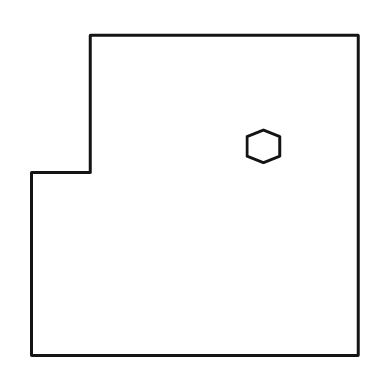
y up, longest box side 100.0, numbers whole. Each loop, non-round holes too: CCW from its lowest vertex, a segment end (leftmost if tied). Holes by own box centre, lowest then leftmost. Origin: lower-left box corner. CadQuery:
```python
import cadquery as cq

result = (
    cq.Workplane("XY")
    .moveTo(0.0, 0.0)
    .lineTo(100.0, 0.0)
    .lineTo(100.0, 98.0)
    .lineTo(18.0, 98.0)
    .lineTo(18.0, 56.0)
    .lineTo(0.0, 56.0)
    .close()
    .moveTo(71.0, 59.0)
    .lineTo(76.0, 61.0)
    .lineTo(76.0, 67.0)
    .lineTo(71.0, 69.0)
    .lineTo(66.0, 67.0)
    .lineTo(66.0, 61.0)
    .close()
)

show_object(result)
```